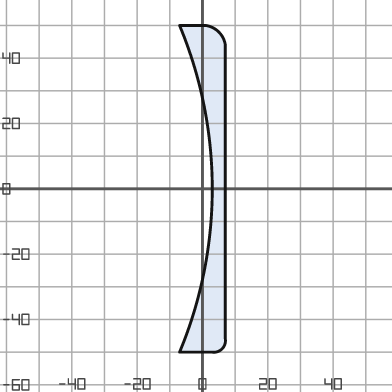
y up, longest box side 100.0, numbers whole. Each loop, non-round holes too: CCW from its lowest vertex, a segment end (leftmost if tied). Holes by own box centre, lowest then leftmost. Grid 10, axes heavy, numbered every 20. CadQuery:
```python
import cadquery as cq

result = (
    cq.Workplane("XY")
    .moveTo(-7.0, -50.0)
    .lineTo(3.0, -50.0)
    .threePointArc((6.0, -49.0), (7.0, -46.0))
    .lineTo(7.0, 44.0)
    .threePointArc((5.0, 48.0), (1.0, 50.0))
    .lineTo(-7.0, 50.0)
    .threePointArc((3.0, 0.0), (-7.0, -50.0))
    .close()
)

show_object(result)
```